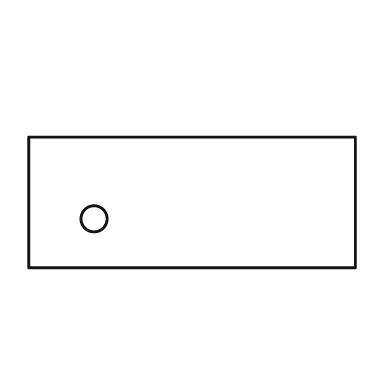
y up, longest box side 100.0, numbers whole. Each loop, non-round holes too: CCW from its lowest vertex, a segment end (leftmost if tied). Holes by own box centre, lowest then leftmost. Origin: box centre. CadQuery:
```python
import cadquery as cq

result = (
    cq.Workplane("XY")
    .moveTo(-50.0, -20.0)
    .lineTo(50.0, -20.0)
    .lineTo(50.0, 20.0)
    .lineTo(-50.0, 20.0)
    .close()
    .moveTo(-30.0, -5.0)
    .circle(4.0)
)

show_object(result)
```